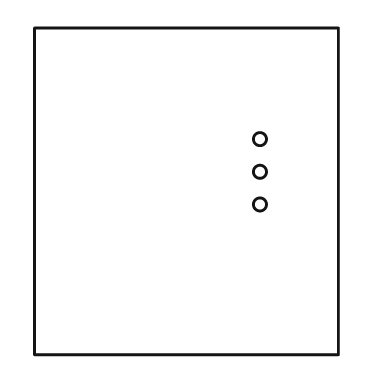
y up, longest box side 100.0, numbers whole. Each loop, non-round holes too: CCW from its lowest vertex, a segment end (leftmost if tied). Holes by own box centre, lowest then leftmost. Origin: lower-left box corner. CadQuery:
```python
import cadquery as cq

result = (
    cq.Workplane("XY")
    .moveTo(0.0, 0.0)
    .lineTo(93.0, 0.0)
    .lineTo(93.0, 100.0)
    .lineTo(0.0, 100.0)
    .close()
    .moveTo(69.0, 46.0)
    .circle(2.0)
    .moveTo(69.0, 56.0)
    .circle(2.0)
    .moveTo(69.0, 66.0)
    .circle(2.0)
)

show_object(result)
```